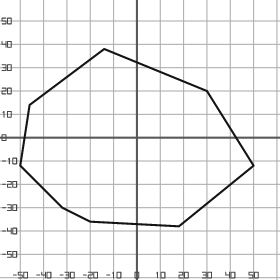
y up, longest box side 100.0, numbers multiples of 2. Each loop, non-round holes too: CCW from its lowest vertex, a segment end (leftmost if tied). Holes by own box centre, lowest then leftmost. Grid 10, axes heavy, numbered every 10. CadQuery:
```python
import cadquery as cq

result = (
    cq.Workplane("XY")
    .moveTo(18.0, -38.0)
    .lineTo(50.0, -12.0)
    .lineTo(30.0, 20.0)
    .lineTo(-14.0, 38.0)
    .lineTo(-46.0, 14.0)
    .lineTo(-50.0, -12.0)
    .lineTo(-32.0, -30.0)
    .lineTo(-20.0, -36.0)
    .close()
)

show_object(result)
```